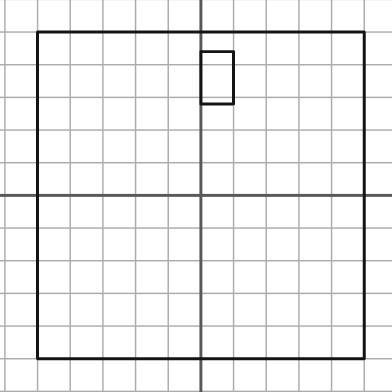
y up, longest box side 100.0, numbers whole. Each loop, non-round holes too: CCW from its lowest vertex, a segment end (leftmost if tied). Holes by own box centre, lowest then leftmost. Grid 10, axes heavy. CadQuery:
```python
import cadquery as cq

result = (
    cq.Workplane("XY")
    .moveTo(-50.0, -50.0)
    .lineTo(50.0, -50.0)
    .lineTo(50.0, 50.0)
    .lineTo(-50.0, 50.0)
    .close()
    .moveTo(0.0, 28.0)
    .lineTo(10.0, 28.0)
    .lineTo(10.0, 44.0)
    .lineTo(0.0, 44.0)
    .close()
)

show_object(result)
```